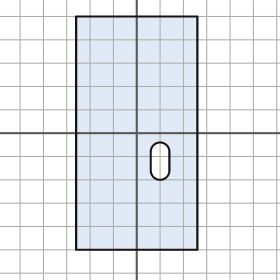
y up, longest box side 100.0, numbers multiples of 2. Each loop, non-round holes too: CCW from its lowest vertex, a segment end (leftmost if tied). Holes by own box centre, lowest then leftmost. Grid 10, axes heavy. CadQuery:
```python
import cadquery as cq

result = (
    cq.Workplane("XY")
    .moveTo(-26.0, -50.0)
    .lineTo(26.0, -50.0)
    .lineTo(26.0, 50.0)
    .lineTo(-26.0, 50.0)
    .close()
    .moveTo(6.0, -16.0)
    .threePointArc((10.0, -20.0), (14.0, -16.0))
    .lineTo(14.0, -8.0)
    .threePointArc((10.0, -4.0), (6.0, -8.0))
    .close()
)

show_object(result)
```